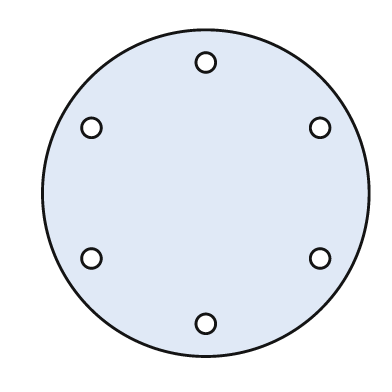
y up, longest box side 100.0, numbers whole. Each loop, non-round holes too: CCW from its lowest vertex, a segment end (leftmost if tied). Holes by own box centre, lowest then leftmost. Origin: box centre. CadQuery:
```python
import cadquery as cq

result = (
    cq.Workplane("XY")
    .moveTo(0.0, 0.0)
    .circle(50.0)
    .moveTo(0.0, -40.0)
    .circle(3.0)
    .moveTo(-35.0, -20.0)
    .circle(3.0)
    .moveTo(35.0, -20.0)
    .circle(3.0)
    .moveTo(-35.0, 20.0)
    .circle(3.0)
    .moveTo(35.0, 20.0)
    .circle(3.0)
    .moveTo(0.0, 40.0)
    .circle(3.0)
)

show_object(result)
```